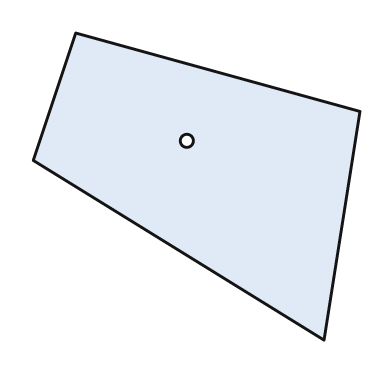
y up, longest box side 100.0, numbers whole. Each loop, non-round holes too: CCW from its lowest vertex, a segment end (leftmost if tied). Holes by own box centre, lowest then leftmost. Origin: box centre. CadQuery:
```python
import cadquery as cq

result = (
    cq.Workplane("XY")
    .moveTo(39.0, -47.0)
    .lineTo(50.0, 23.0)
    .lineTo(-37.0, 47.0)
    .lineTo(-50.0, 8.0)
    .close()
    .moveTo(-3.0, 14.0)
    .circle(2.0)
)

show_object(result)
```